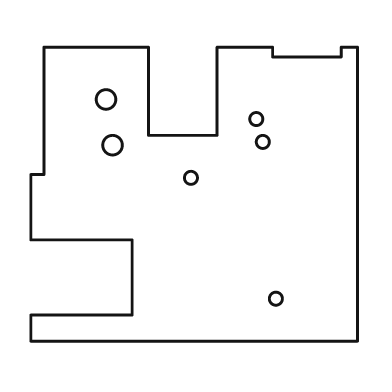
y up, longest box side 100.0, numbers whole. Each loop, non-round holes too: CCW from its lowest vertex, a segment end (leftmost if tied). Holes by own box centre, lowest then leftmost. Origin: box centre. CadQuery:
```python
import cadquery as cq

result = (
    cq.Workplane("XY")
    .moveTo(-50.0, -45.0)
    .lineTo(50.0, -45.0)
    .lineTo(50.0, 45.0)
    .lineTo(45.0, 45.0)
    .lineTo(45.0, 42.0)
    .lineTo(24.0, 42.0)
    .lineTo(24.0, 45.0)
    .lineTo(7.0, 45.0)
    .lineTo(7.0, 18.0)
    .lineTo(-14.0, 18.0)
    .lineTo(-14.0, 45.0)
    .lineTo(-46.0, 45.0)
    .lineTo(-46.0, 6.0)
    .lineTo(-50.0, 6.0)
    .lineTo(-50.0, -14.0)
    .lineTo(-19.0, -14.0)
    .lineTo(-19.0, -37.0)
    .lineTo(-50.0, -37.0)
    .close()
    .moveTo(25.0, -32.0)
    .circle(2.0)
    .moveTo(-1.0, 5.0)
    .circle(2.0)
    .moveTo(-25.0, 15.0)
    .circle(3.0)
    .moveTo(21.0, 16.0)
    .circle(2.0)
    .moveTo(19.0, 23.0)
    .circle(2.0)
    .moveTo(-27.0, 29.0)
    .circle(3.0)
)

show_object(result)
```